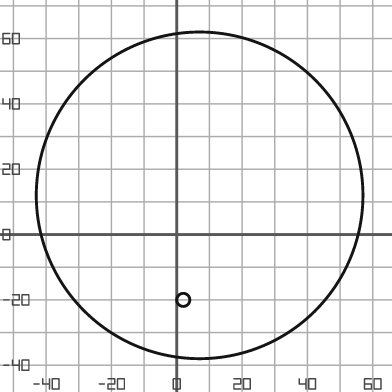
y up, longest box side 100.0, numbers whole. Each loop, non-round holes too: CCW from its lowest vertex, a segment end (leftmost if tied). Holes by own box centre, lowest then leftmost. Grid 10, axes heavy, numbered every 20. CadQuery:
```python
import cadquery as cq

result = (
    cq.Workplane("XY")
    .moveTo(7.0, 12.0)
    .circle(50.0)
    .moveTo(2.0, -20.0)
    .circle(2.0)
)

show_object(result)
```